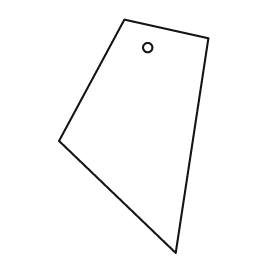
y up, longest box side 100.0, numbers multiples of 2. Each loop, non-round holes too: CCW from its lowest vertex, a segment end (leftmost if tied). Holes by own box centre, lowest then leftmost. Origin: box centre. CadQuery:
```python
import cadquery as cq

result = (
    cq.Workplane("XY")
    .moveTo(18.0, -50.0)
    .lineTo(32.0, 42.0)
    .lineTo(-4.0, 50.0)
    .lineTo(-32.0, -2.0)
    .close()
    .moveTo(6.0, 38.0)
    .circle(2.0)
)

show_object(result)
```